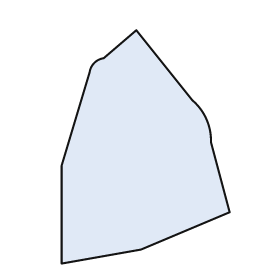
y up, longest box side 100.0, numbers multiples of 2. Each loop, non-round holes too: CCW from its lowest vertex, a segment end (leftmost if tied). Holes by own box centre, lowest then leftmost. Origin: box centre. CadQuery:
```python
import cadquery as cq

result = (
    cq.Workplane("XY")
    .moveTo(-36.0, -50.0)
    .lineTo(-2.0, -44.0)
    .lineTo(36.0, -28.0)
    .lineTo(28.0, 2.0)
    .threePointArc((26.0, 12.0), (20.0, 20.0))
    .lineTo(-4.0, 50.0)
    .lineTo(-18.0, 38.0)
    .threePointArc((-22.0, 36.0), (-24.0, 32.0))
    .lineTo(-36.0, -8.0)
    .close()
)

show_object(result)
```